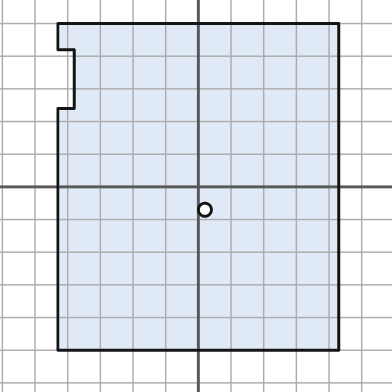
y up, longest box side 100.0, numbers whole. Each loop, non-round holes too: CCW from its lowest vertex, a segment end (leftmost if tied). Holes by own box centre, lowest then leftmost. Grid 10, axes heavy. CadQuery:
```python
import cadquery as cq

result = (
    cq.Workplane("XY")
    .moveTo(-43.0, -50.0)
    .lineTo(43.0, -50.0)
    .lineTo(43.0, 50.0)
    .lineTo(-43.0, 50.0)
    .lineTo(-43.0, 42.0)
    .lineTo(-38.0, 42.0)
    .lineTo(-38.0, 24.0)
    .lineTo(-43.0, 24.0)
    .close()
    .moveTo(2.0, -7.0)
    .circle(2.0)
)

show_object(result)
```